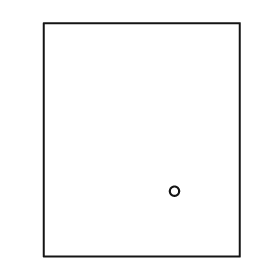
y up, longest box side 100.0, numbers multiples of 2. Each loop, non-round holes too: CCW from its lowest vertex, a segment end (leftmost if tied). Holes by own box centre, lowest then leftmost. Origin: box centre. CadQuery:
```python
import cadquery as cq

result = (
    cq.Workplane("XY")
    .moveTo(-42.0, -50.0)
    .lineTo(42.0, -50.0)
    .lineTo(42.0, 50.0)
    .lineTo(-42.0, 50.0)
    .close()
    .moveTo(14.0, -22.0)
    .circle(2.0)
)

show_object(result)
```